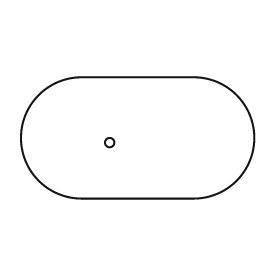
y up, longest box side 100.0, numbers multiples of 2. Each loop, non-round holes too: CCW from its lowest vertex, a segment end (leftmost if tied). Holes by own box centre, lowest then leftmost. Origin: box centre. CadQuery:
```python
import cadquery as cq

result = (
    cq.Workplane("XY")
    .moveTo(-24.0, -26.0)
    .lineTo(24.0, -26.0)
    .threePointArc((50.0, 0.0), (24.0, 26.0))
    .lineTo(-24.0, 26.0)
    .threePointArc((-50.0, 0.0), (-24.0, -26.0))
    .close()
    .moveTo(-12.0, -2.0)
    .circle(2.0)
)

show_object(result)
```